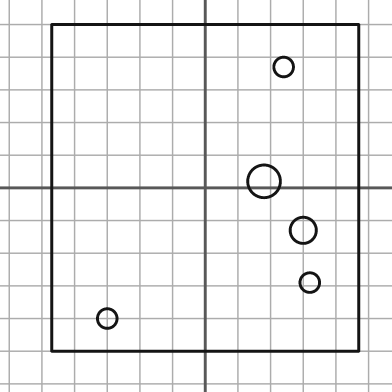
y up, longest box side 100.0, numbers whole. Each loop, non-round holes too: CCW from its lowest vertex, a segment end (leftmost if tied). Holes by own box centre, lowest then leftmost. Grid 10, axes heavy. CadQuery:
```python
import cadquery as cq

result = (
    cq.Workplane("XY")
    .moveTo(-47.0, -50.0)
    .lineTo(47.0, -50.0)
    .lineTo(47.0, 50.0)
    .lineTo(-47.0, 50.0)
    .close()
    .moveTo(-30.0, -40.0)
    .circle(3.0)
    .moveTo(32.0, -29.0)
    .circle(3.0)
    .moveTo(30.0, -13.0)
    .circle(4.0)
    .moveTo(18.0, 2.0)
    .circle(5.0)
    .moveTo(24.0, 37.0)
    .circle(3.0)
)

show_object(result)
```